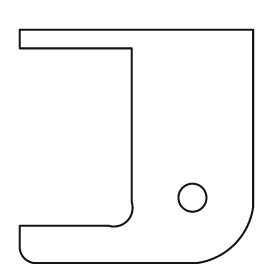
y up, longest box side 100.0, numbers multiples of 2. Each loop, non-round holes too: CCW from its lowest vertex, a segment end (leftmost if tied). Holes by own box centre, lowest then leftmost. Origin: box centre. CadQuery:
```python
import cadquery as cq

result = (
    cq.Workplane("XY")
    .moveTo(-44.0, -50.0)
    .lineTo(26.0, -50.0)
    .threePointArc((42.0, -42.0), (50.0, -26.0))
    .lineTo(50.0, 50.0)
    .lineTo(-50.0, 50.0)
    .lineTo(-50.0, 42.0)
    .lineTo(-2.0, 42.0)
    .lineTo(-2.0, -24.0)
    .threePointArc((-4.0, -32.0), (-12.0, -34.0))
    .lineTo(-50.0, -34.0)
    .lineTo(-50.0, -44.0)
    .threePointArc((-48.0, -48.0), (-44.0, -50.0))
    .close()
    .moveTo(24.0, -22.0)
    .circle(6.0)
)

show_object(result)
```